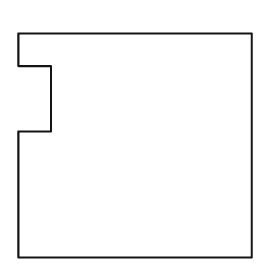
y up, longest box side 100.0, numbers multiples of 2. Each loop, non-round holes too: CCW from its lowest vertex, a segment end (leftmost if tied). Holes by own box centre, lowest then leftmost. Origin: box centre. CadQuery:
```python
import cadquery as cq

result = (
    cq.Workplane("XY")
    .moveTo(-50.0, -48.0)
    .lineTo(50.0, -48.0)
    .lineTo(50.0, 48.0)
    .lineTo(-50.0, 48.0)
    .lineTo(-50.0, 34.0)
    .lineTo(-36.0, 34.0)
    .lineTo(-36.0, 6.0)
    .lineTo(-50.0, 6.0)
    .close()
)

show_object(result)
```